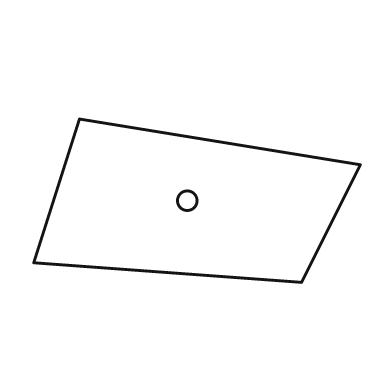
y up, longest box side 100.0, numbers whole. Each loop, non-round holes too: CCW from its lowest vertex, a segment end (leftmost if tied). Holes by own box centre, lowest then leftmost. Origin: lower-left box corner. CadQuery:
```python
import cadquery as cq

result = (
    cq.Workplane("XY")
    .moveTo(82.0, 0.0)
    .lineTo(100.0, 36.0)
    .lineTo(14.0, 50.0)
    .lineTo(0.0, 6.0)
    .close()
    .moveTo(47.0, 25.0)
    .circle(3.0)
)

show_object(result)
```